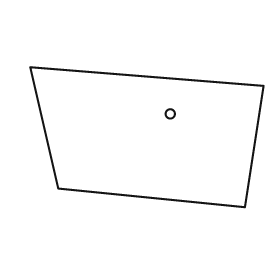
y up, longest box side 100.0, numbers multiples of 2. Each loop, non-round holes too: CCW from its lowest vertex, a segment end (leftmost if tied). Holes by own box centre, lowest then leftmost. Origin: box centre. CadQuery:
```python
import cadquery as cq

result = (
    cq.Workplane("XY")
    .moveTo(42.0, -30.0)
    .lineTo(50.0, 22.0)
    .lineTo(-50.0, 30.0)
    .lineTo(-38.0, -22.0)
    .close()
    .moveTo(10.0, 10.0)
    .circle(2.0)
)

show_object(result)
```